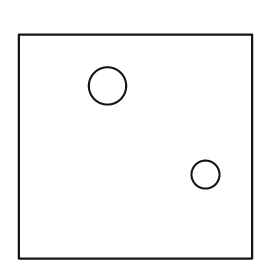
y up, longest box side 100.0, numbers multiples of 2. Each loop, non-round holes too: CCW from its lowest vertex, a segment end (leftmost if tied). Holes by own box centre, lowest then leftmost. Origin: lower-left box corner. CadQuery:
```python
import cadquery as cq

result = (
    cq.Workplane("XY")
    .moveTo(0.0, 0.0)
    .lineTo(100.0, 0.0)
    .lineTo(100.0, 96.0)
    .lineTo(0.0, 96.0)
    .close()
    .moveTo(80.0, 36.0)
    .circle(6.0)
    .moveTo(38.0, 74.0)
    .circle(8.0)
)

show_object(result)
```